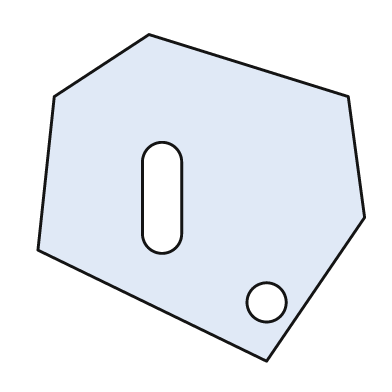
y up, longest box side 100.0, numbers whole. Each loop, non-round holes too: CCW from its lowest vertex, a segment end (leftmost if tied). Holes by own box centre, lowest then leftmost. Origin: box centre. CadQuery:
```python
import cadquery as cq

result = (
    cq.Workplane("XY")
    .moveTo(20.0, -50.0)
    .lineTo(50.0, -6.0)
    .lineTo(45.0, 31.0)
    .lineTo(-16.0, 50.0)
    .lineTo(-45.0, 31.0)
    .lineTo(-50.0, -16.0)
    .close()
    .moveTo(20.0, -32.0)
    .circle(6.0)
    .moveTo(-18.0, -11.0)
    .threePointArc((-12.0, -17.0), (-6.0, -11.0))
    .lineTo(-6.0, 11.0)
    .threePointArc((-12.0, 17.0), (-18.0, 11.0))
    .close()
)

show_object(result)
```